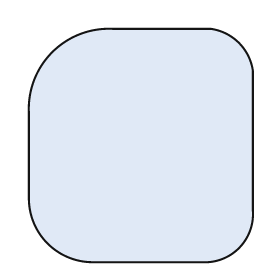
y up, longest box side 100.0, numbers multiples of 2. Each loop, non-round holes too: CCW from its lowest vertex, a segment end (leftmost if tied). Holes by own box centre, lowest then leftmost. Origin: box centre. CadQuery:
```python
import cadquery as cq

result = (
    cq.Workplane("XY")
    .moveTo(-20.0, -50.0)
    .lineTo(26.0, -50.0)
    .threePointArc((42.0, -44.0), (48.0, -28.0))
    .lineTo(48.0, 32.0)
    .threePointArc((42.0, 44.0), (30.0, 50.0))
    .lineTo(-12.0, 50.0)
    .threePointArc((-38.0, 40.0), (-48.0, 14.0))
    .lineTo(-48.0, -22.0)
    .threePointArc((-40.0, -42.0), (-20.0, -50.0))
    .close()
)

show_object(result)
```